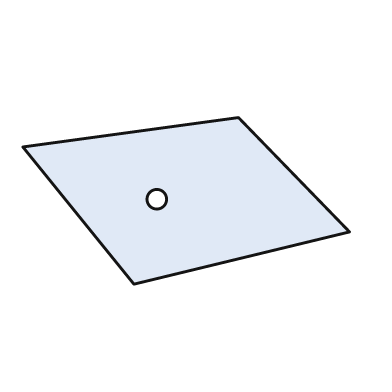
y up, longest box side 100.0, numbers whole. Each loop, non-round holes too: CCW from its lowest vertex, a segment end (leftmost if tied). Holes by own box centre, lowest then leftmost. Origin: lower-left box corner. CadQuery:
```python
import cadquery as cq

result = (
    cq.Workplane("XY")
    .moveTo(34.0, 0.0)
    .lineTo(100.0, 16.0)
    .lineTo(66.0, 51.0)
    .lineTo(0.0, 42.0)
    .close()
    .moveTo(41.0, 26.0)
    .circle(3.0)
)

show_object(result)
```